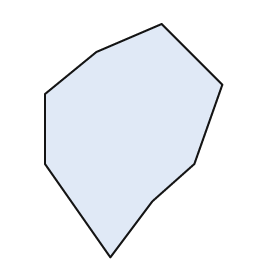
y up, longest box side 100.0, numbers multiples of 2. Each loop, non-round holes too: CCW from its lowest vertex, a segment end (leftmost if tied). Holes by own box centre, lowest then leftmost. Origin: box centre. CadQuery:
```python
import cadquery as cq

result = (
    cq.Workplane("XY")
    .moveTo(-10.0, -50.0)
    .lineTo(8.0, -26.0)
    .lineTo(26.0, -10.0)
    .lineTo(38.0, 24.0)
    .lineTo(12.0, 50.0)
    .lineTo(-16.0, 38.0)
    .lineTo(-38.0, 20.0)
    .lineTo(-38.0, -10.0)
    .close()
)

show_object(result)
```